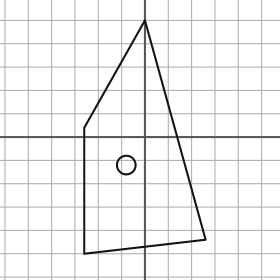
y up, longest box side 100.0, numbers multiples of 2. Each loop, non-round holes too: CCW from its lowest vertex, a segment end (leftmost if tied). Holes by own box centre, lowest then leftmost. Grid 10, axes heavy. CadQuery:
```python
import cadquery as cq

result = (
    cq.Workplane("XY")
    .moveTo(-26.0, -50.0)
    .lineTo(26.0, -44.0)
    .lineTo(0.0, 50.0)
    .lineTo(-26.0, 4.0)
    .close()
    .moveTo(-8.0, -12.0)
    .circle(4.0)
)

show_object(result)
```